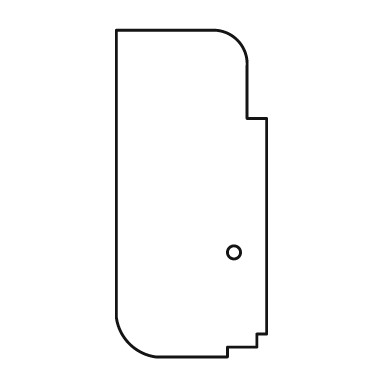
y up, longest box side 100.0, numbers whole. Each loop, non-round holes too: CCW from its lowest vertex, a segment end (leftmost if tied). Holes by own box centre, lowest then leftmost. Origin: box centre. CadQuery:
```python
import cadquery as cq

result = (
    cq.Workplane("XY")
    .moveTo(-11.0, -50.0)
    .lineTo(11.0, -50.0)
    .lineTo(11.0, -47.0)
    .lineTo(20.0, -47.0)
    .lineTo(20.0, -43.0)
    .lineTo(23.0, -43.0)
    .lineTo(23.0, 23.0)
    .lineTo(17.0, 23.0)
    .lineTo(17.0, 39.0)
    .threePointArc((14.0, 47.0), (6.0, 50.0))
    .lineTo(-23.0, 50.0)
    .lineTo(-23.0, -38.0)
    .threePointArc((-19.0, -46.0), (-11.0, -50.0))
    .close()
    .moveTo(13.0, -18.0)
    .circle(2.0)
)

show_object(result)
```